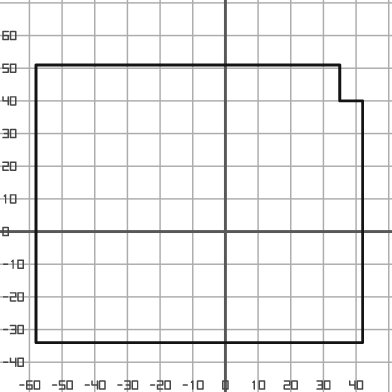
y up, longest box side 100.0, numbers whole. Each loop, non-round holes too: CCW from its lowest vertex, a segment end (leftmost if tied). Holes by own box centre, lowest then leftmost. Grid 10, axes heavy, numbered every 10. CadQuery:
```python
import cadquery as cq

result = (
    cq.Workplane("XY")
    .moveTo(-58.0, -34.0)
    .lineTo(42.0, -34.0)
    .lineTo(42.0, 40.0)
    .lineTo(35.0, 40.0)
    .lineTo(35.0, 51.0)
    .lineTo(-58.0, 51.0)
    .close()
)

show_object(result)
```